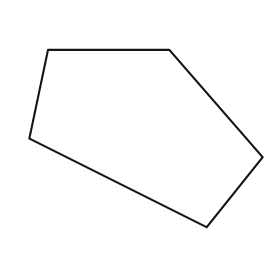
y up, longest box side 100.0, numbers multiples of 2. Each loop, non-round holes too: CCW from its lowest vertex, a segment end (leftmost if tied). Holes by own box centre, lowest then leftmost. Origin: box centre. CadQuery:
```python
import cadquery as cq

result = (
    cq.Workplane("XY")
    .moveTo(26.0, -38.0)
    .lineTo(50.0, -8.0)
    .lineTo(10.0, 38.0)
    .lineTo(-42.0, 38.0)
    .lineTo(-50.0, 0.0)
    .close()
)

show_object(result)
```